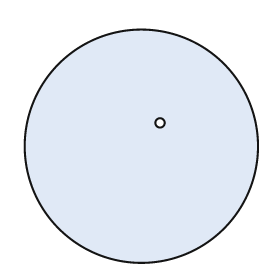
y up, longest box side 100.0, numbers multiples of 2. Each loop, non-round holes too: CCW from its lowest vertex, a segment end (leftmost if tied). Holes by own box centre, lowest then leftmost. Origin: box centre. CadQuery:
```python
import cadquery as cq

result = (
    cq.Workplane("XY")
    .moveTo(0.0, 0.0)
    .circle(50.0)
    .moveTo(8.0, 10.0)
    .circle(2.0)
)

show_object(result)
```